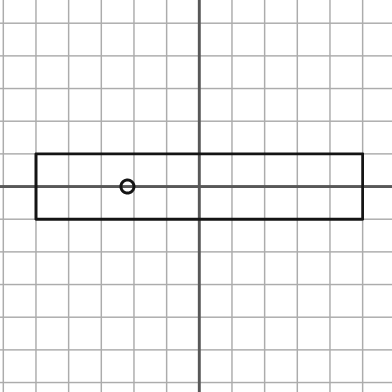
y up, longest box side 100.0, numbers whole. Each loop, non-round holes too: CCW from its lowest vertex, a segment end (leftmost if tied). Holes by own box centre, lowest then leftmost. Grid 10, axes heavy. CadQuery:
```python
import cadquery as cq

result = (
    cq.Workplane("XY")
    .moveTo(-50.0, -10.0)
    .lineTo(50.0, -10.0)
    .lineTo(50.0, 10.0)
    .lineTo(-50.0, 10.0)
    .close()
    .moveTo(-22.0, 0.0)
    .circle(2.0)
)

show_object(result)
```